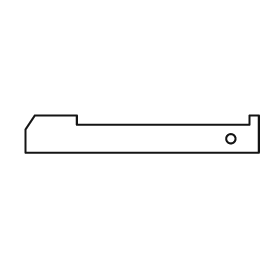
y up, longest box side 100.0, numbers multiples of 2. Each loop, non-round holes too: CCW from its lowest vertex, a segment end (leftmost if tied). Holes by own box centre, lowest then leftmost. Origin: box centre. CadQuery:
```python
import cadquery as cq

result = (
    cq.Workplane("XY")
    .moveTo(-50.0, -8.0)
    .lineTo(50.0, -8.0)
    .lineTo(50.0, 8.0)
    .lineTo(46.0, 8.0)
    .lineTo(46.0, 4.0)
    .lineTo(-28.0, 4.0)
    .lineTo(-28.0, 8.0)
    .lineTo(-46.0, 8.0)
    .lineTo(-50.0, 2.0)
    .close()
    .moveTo(38.0, -2.0)
    .circle(2.0)
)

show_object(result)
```